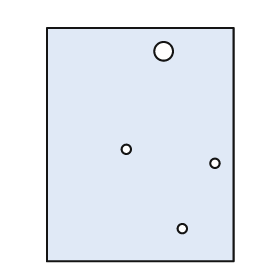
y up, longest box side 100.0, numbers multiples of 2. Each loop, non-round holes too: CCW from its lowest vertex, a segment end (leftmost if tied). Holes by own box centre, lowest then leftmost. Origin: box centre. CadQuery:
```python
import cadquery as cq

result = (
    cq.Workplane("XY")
    .moveTo(-40.0, -50.0)
    .lineTo(40.0, -50.0)
    .lineTo(40.0, 50.0)
    .lineTo(-40.0, 50.0)
    .close()
    .moveTo(18.0, -36.0)
    .circle(2.0)
    .moveTo(32.0, -8.0)
    .circle(2.0)
    .moveTo(-6.0, -2.0)
    .circle(2.0)
    .moveTo(10.0, 40.0)
    .circle(4.0)
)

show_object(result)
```